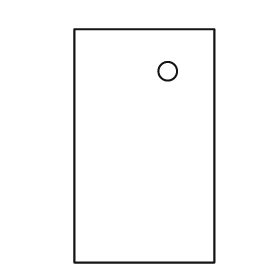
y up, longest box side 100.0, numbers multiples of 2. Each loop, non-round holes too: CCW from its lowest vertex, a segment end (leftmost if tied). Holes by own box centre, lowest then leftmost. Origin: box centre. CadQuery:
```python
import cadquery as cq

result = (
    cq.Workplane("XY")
    .moveTo(-30.0, -50.0)
    .lineTo(30.0, -50.0)
    .lineTo(30.0, 50.0)
    .lineTo(-30.0, 50.0)
    .close()
    .moveTo(10.0, 32.0)
    .circle(4.0)
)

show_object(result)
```